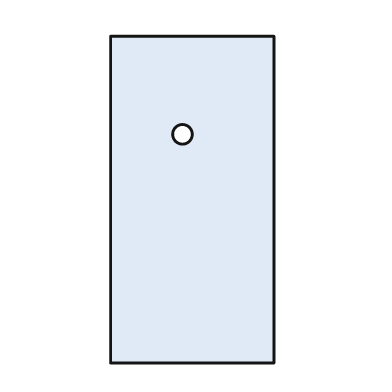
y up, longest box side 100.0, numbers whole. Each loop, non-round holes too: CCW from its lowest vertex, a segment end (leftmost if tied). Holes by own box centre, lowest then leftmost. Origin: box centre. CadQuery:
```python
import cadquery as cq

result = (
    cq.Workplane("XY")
    .moveTo(-25.0, -50.0)
    .lineTo(25.0, -50.0)
    .lineTo(25.0, 50.0)
    .lineTo(-25.0, 50.0)
    .close()
    .moveTo(-3.0, 20.0)
    .circle(3.0)
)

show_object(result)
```